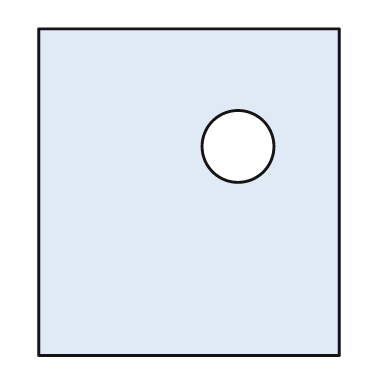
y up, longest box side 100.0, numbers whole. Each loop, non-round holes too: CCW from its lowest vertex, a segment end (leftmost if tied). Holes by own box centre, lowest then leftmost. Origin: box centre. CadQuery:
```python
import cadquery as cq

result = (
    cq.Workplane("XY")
    .moveTo(-46.0, -50.0)
    .lineTo(46.0, -50.0)
    .lineTo(46.0, 50.0)
    .lineTo(-46.0, 50.0)
    .close()
    .moveTo(15.0, 14.0)
    .circle(11.0)
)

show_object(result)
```